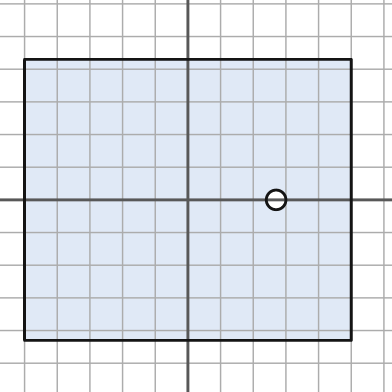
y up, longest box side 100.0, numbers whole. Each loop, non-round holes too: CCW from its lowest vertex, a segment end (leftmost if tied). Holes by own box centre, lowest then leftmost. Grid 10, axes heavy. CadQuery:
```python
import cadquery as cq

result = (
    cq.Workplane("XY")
    .moveTo(-50.0, -43.0)
    .lineTo(50.0, -43.0)
    .lineTo(50.0, 43.0)
    .lineTo(-50.0, 43.0)
    .close()
    .moveTo(27.0, 0.0)
    .circle(3.0)
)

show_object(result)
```